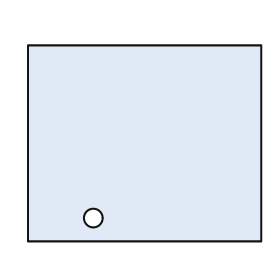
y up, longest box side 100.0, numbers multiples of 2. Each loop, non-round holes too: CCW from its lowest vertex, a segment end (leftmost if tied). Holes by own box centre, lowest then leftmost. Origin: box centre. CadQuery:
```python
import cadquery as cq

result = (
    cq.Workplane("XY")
    .moveTo(-50.0, -42.0)
    .lineTo(50.0, -42.0)
    .lineTo(50.0, 42.0)
    .lineTo(-50.0, 42.0)
    .close()
    .moveTo(-22.0, -32.0)
    .circle(4.0)
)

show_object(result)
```